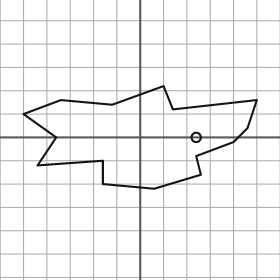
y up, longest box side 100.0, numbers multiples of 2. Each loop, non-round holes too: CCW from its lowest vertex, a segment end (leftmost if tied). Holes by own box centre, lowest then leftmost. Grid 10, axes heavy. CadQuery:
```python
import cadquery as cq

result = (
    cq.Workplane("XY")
    .moveTo(6.0, -22.0)
    .lineTo(26.0, -16.0)
    .lineTo(24.0, -8.0)
    .lineTo(40.0, -2.0)
    .lineTo(46.0, 4.0)
    .lineTo(50.0, 16.0)
    .lineTo(14.0, 12.0)
    .lineTo(10.0, 22.0)
    .lineTo(-12.0, 14.0)
    .lineTo(-34.0, 16.0)
    .lineTo(-50.0, 10.0)
    .lineTo(-36.0, 0.0)
    .lineTo(-44.0, -12.0)
    .lineTo(-16.0, -10.0)
    .lineTo(-16.0, -20.0)
    .close()
    .moveTo(24.0, 0.0)
    .circle(2.0)
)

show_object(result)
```